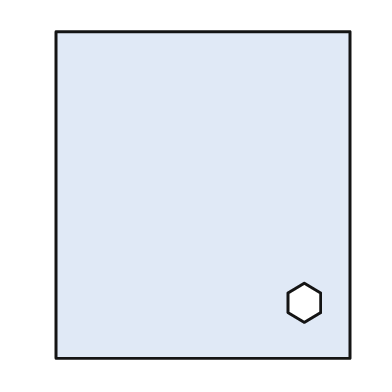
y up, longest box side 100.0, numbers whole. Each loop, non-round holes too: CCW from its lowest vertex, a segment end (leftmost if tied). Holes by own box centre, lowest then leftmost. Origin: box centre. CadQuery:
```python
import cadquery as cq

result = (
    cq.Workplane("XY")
    .moveTo(-45.0, -50.0)
    .lineTo(45.0, -50.0)
    .lineTo(45.0, 50.0)
    .lineTo(-45.0, 50.0)
    .close()
    .moveTo(31.0, -39.0)
    .lineTo(36.0, -36.0)
    .lineTo(36.0, -30.0)
    .lineTo(31.0, -27.0)
    .lineTo(26.0, -30.0)
    .lineTo(26.0, -36.0)
    .close()
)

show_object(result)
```